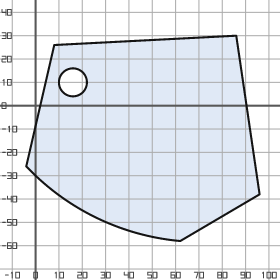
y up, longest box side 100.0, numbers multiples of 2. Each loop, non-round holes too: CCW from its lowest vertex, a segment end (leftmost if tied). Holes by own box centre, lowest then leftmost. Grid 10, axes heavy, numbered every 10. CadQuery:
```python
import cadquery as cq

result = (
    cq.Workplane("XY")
    .moveTo(62.0, -58.0)
    .lineTo(96.0, -38.0)
    .lineTo(86.0, 30.0)
    .lineTo(8.0, 26.0)
    .lineTo(-4.0, -26.0)
    .threePointArc((26.0, -48.0), (62.0, -58.0))
    .close()
    .moveTo(16.0, 10.0)
    .circle(6.0)
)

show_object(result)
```